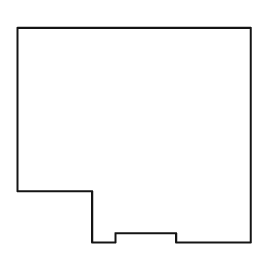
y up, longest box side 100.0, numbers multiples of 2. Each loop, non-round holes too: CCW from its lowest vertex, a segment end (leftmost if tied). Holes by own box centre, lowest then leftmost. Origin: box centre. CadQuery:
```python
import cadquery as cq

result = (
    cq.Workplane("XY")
    .moveTo(-18.0, -46.0)
    .lineTo(-8.0, -46.0)
    .lineTo(-8.0, -42.0)
    .lineTo(18.0, -42.0)
    .lineTo(18.0, -46.0)
    .lineTo(50.0, -46.0)
    .lineTo(50.0, 46.0)
    .lineTo(-50.0, 46.0)
    .lineTo(-50.0, -24.0)
    .lineTo(-18.0, -24.0)
    .close()
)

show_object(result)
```